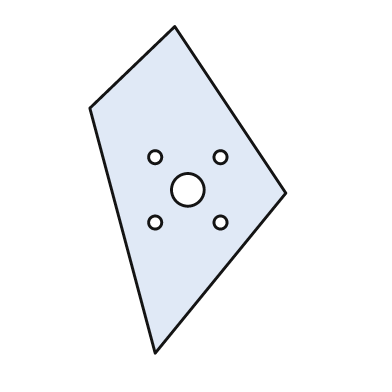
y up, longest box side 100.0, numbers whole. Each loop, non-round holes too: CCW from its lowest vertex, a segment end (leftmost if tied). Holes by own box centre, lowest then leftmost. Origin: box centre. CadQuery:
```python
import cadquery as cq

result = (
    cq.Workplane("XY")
    .moveTo(-10.0, -50.0)
    .lineTo(30.0, -1.0)
    .lineTo(-4.0, 50.0)
    .lineTo(-30.0, 25.0)
    .close()
    .moveTo(-10.0, -10.0)
    .circle(2.0)
    .moveTo(10.0, -10.0)
    .circle(2.0)
    .moveTo(0.0, 0.0)
    .circle(5.0)
    .moveTo(-10.0, 10.0)
    .circle(2.0)
    .moveTo(10.0, 10.0)
    .circle(2.0)
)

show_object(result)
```